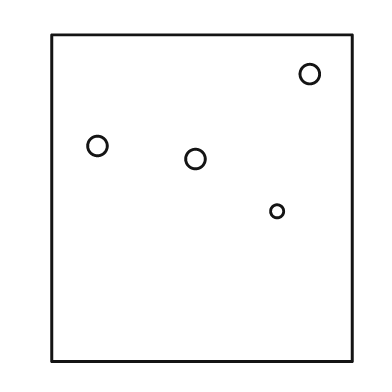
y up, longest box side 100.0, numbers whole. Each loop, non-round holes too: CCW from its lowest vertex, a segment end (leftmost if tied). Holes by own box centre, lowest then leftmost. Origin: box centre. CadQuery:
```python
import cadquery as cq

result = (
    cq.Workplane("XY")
    .moveTo(-46.0, -50.0)
    .lineTo(46.0, -50.0)
    .lineTo(46.0, 50.0)
    .lineTo(-46.0, 50.0)
    .close()
    .moveTo(23.0, -4.0)
    .circle(2.0)
    .moveTo(-2.0, 12.0)
    .circle(3.0)
    .moveTo(-32.0, 16.0)
    .circle(3.0)
    .moveTo(33.0, 38.0)
    .circle(3.0)
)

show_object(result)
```